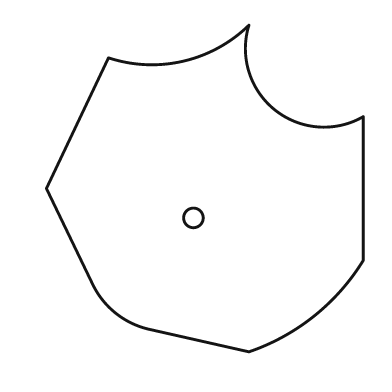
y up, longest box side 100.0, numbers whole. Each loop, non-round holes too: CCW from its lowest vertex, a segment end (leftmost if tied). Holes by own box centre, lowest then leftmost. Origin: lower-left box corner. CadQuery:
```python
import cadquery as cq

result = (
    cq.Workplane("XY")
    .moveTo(62.0, 0.0)
    .threePointArc((82.0, 11.0), (97.0, 28.0))
    .lineTo(97.0, 72.0)
    .threePointArc((70.0, 74.0), (62.0, 100.0))
    .threePointArc((42.0, 89.0), (19.0, 90.0))
    .lineTo(0.0, 50.0)
    .lineTo(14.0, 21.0)
    .threePointArc((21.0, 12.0), (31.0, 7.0))
    .close()
    .moveTo(45.0, 41.0)
    .circle(3.0)
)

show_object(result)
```